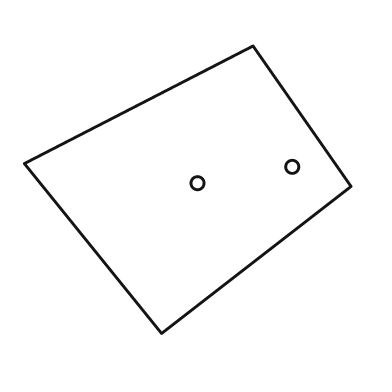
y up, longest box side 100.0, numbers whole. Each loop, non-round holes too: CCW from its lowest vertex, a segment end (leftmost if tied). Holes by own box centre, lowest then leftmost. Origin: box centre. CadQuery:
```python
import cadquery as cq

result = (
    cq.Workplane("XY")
    .moveTo(-8.0, -44.0)
    .lineTo(50.0, 1.0)
    .lineTo(20.0, 44.0)
    .lineTo(-50.0, 8.0)
    .close()
    .moveTo(3.0, 2.0)
    .circle(2.0)
    .moveTo(32.0, 7.0)
    .circle(2.0)
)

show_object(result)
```